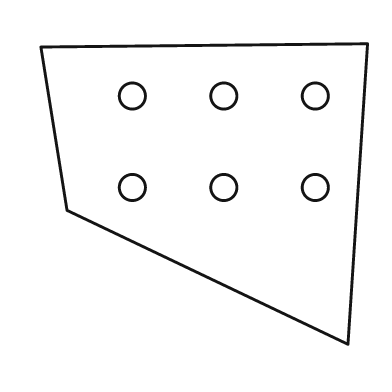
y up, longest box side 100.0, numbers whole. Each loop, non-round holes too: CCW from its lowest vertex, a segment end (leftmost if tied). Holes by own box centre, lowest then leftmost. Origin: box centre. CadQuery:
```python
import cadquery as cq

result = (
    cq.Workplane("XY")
    .moveTo(44.0, -46.0)
    .lineTo(50.0, 46.0)
    .lineTo(-50.0, 45.0)
    .lineTo(-42.0, -5.0)
    .close()
    .moveTo(-22.0, 2.0)
    .circle(4.0)
    .moveTo(6.0, 2.0)
    .circle(4.0)
    .moveTo(34.0, 2.0)
    .circle(4.0)
    .moveTo(-22.0, 30.0)
    .circle(4.0)
    .moveTo(6.0, 30.0)
    .circle(4.0)
    .moveTo(34.0, 30.0)
    .circle(4.0)
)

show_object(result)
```